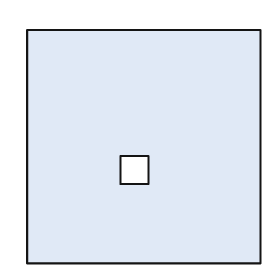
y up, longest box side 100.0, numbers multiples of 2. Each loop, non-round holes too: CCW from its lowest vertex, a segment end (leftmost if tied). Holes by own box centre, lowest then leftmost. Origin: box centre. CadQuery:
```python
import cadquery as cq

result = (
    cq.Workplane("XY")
    .moveTo(-50.0, -50.0)
    .lineTo(50.0, -50.0)
    .lineTo(50.0, 50.0)
    .lineTo(-50.0, 50.0)
    .close()
    .moveTo(-10.0, -16.0)
    .lineTo(2.0, -16.0)
    .lineTo(2.0, -4.0)
    .lineTo(-10.0, -4.0)
    .close()
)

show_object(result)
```